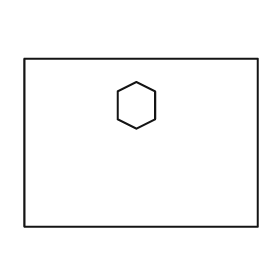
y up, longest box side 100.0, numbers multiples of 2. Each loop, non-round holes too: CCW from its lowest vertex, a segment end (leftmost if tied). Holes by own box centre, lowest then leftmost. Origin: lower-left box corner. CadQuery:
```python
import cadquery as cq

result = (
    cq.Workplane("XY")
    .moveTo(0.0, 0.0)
    .lineTo(100.0, 0.0)
    .lineTo(100.0, 72.0)
    .lineTo(0.0, 72.0)
    .close()
    .moveTo(48.0, 42.0)
    .lineTo(56.0, 46.0)
    .lineTo(56.0, 58.0)
    .lineTo(48.0, 62.0)
    .lineTo(40.0, 58.0)
    .lineTo(40.0, 46.0)
    .close()
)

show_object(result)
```